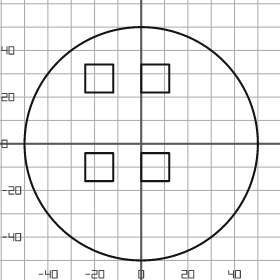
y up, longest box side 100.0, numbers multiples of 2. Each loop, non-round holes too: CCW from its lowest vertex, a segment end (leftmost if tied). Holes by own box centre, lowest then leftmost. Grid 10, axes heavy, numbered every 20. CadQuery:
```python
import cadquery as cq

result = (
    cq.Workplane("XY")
    .moveTo(0.0, 0.0)
    .circle(50.0)
    .moveTo(-24.0, -16.0)
    .lineTo(-12.0, -16.0)
    .lineTo(-12.0, -4.0)
    .lineTo(-24.0, -4.0)
    .close()
    .moveTo(0.0, -16.0)
    .lineTo(12.0, -16.0)
    .lineTo(12.0, -4.0)
    .lineTo(0.0, -4.0)
    .close()
    .moveTo(-24.0, 22.0)
    .lineTo(-12.0, 22.0)
    .lineTo(-12.0, 34.0)
    .lineTo(-24.0, 34.0)
    .close()
    .moveTo(0.0, 22.0)
    .lineTo(12.0, 22.0)
    .lineTo(12.0, 34.0)
    .lineTo(0.0, 34.0)
    .close()
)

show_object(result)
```